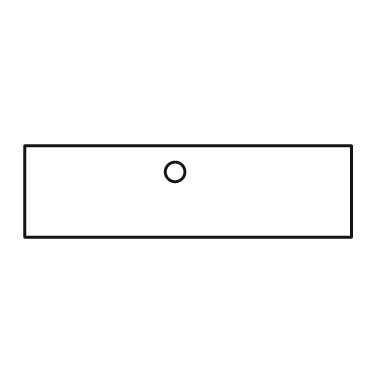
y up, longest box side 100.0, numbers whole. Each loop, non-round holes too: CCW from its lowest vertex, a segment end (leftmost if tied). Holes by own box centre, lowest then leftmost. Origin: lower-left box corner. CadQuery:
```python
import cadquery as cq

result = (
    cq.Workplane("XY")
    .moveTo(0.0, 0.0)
    .lineTo(100.0, 0.0)
    .lineTo(100.0, 28.0)
    .lineTo(0.0, 28.0)
    .close()
    .moveTo(46.0, 20.0)
    .circle(3.0)
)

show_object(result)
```